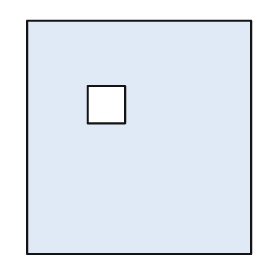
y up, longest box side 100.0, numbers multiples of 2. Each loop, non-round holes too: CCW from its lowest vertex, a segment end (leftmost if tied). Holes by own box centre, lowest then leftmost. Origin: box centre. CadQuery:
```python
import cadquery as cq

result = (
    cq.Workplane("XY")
    .moveTo(-48.0, -50.0)
    .lineTo(48.0, -50.0)
    .lineTo(48.0, 50.0)
    .lineTo(-48.0, 50.0)
    .close()
    .moveTo(-22.0, 6.0)
    .lineTo(-6.0, 6.0)
    .lineTo(-6.0, 22.0)
    .lineTo(-22.0, 22.0)
    .close()
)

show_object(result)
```